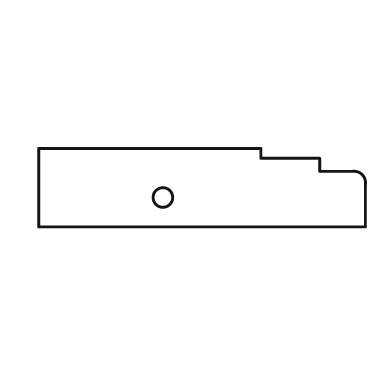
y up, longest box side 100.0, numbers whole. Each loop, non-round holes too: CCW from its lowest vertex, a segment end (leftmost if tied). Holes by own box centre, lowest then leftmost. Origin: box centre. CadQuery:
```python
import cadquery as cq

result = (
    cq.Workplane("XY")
    .moveTo(-50.0, -12.0)
    .lineTo(50.0, -12.0)
    .lineTo(50.0, 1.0)
    .threePointArc((49.0, 4.0), (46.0, 5.0))
    .lineTo(36.0, 5.0)
    .lineTo(36.0, 9.0)
    .lineTo(18.0, 9.0)
    .lineTo(18.0, 12.0)
    .lineTo(-50.0, 12.0)
    .close()
    .moveTo(-12.0, -3.0)
    .circle(3.0)
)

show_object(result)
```